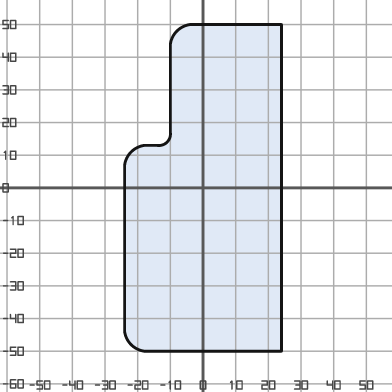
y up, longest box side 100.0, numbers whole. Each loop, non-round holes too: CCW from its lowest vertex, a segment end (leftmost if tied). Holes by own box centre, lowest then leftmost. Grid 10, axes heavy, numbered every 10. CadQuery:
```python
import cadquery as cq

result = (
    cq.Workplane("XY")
    .moveTo(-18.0, -50.0)
    .lineTo(24.0, -50.0)
    .lineTo(24.0, 50.0)
    .lineTo(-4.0, 50.0)
    .threePointArc((-8.0, 48.0), (-10.0, 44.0))
    .lineTo(-10.0, 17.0)
    .threePointArc((-11.0, 14.0), (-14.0, 13.0))
    .lineTo(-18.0, 13.0)
    .threePointArc((-22.0, 11.0), (-24.0, 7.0))
    .lineTo(-24.0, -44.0)
    .threePointArc((-22.0, -48.0), (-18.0, -50.0))
    .close()
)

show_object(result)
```